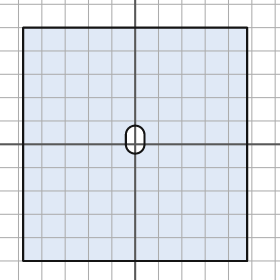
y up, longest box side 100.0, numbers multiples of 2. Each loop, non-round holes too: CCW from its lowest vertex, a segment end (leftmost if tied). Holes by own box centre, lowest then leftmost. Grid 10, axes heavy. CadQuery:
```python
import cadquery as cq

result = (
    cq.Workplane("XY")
    .moveTo(-48.0, -50.0)
    .lineTo(48.0, -50.0)
    .lineTo(48.0, 50.0)
    .lineTo(-48.0, 50.0)
    .close()
    .moveTo(-4.0, 0.0)
    .threePointArc((0.0, -4.0), (4.0, 0.0))
    .lineTo(4.0, 4.0)
    .threePointArc((0.0, 8.0), (-4.0, 4.0))
    .close()
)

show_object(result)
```